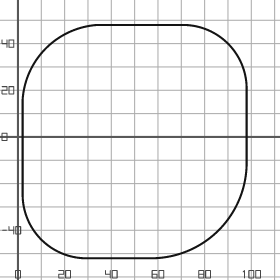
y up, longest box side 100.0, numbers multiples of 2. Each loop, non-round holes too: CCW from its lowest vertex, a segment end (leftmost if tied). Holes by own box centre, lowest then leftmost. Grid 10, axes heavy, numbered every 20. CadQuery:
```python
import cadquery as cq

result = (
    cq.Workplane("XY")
    .moveTo(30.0, -52.0)
    .lineTo(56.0, -52.0)
    .threePointArc((86.0, -40.0), (98.0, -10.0))
    .lineTo(98.0, 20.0)
    .threePointArc((90.0, 40.0), (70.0, 48.0))
    .lineTo(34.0, 48.0)
    .threePointArc((12.0, 38.0), (2.0, 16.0))
    .lineTo(2.0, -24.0)
    .threePointArc((10.0, -44.0), (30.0, -52.0))
    .close()
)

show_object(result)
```